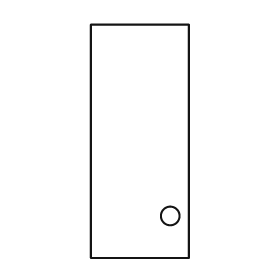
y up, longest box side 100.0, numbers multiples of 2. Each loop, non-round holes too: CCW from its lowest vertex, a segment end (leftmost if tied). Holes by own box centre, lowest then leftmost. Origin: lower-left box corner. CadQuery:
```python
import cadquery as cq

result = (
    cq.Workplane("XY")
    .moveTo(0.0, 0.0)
    .lineTo(42.0, 0.0)
    .lineTo(42.0, 100.0)
    .lineTo(0.0, 100.0)
    .close()
    .moveTo(34.0, 18.0)
    .circle(4.0)
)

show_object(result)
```